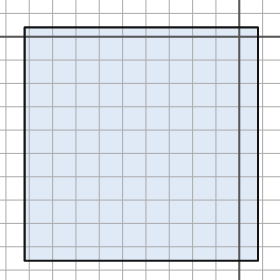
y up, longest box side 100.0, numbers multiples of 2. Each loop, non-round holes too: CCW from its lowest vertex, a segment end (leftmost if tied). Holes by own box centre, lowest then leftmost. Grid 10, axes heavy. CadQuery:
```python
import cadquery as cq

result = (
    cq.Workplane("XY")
    .moveTo(-92.0, -96.0)
    .lineTo(8.0, -96.0)
    .lineTo(8.0, 4.0)
    .lineTo(-92.0, 4.0)
    .close()
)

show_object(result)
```